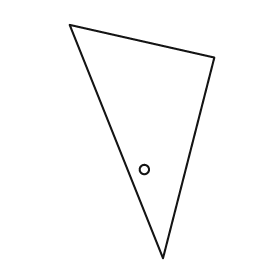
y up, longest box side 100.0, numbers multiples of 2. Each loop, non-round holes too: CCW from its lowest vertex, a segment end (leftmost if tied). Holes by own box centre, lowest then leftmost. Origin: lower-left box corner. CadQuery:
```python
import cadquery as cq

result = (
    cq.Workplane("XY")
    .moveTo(40.0, 0.0)
    .lineTo(62.0, 86.0)
    .lineTo(0.0, 100.0)
    .close()
    .moveTo(32.0, 38.0)
    .circle(2.0)
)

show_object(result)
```